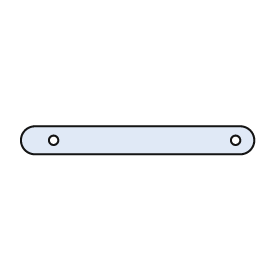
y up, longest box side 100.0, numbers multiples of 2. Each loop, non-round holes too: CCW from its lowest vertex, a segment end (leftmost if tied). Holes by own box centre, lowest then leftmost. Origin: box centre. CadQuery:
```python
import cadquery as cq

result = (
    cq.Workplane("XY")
    .moveTo(-44.0, -6.0)
    .lineTo(44.0, -6.0)
    .threePointArc((50.0, 0.0), (44.0, 6.0))
    .lineTo(-44.0, 6.0)
    .threePointArc((-50.0, 0.0), (-44.0, -6.0))
    .close()
    .moveTo(-36.0, 0.0)
    .circle(2.0)
    .moveTo(42.0, 0.0)
    .circle(2.0)
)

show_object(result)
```